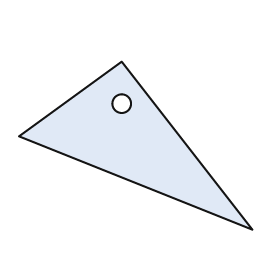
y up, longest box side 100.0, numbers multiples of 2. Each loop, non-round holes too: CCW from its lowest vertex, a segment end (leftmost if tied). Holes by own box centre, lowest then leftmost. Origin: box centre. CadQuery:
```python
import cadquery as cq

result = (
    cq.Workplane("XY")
    .moveTo(50.0, -36.0)
    .lineTo(-6.0, 36.0)
    .lineTo(-50.0, 4.0)
    .close()
    .moveTo(-6.0, 18.0)
    .circle(4.0)
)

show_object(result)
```